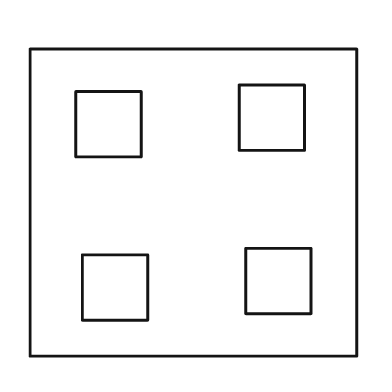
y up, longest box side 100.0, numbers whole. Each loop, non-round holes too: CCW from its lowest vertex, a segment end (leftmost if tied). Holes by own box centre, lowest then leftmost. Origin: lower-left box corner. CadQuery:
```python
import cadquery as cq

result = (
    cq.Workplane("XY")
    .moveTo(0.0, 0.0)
    .lineTo(100.0, 0.0)
    .lineTo(100.0, 94.0)
    .lineTo(0.0, 94.0)
    .close()
    .moveTo(16.0, 11.0)
    .lineTo(36.0, 11.0)
    .lineTo(36.0, 31.0)
    .lineTo(16.0, 31.0)
    .close()
    .moveTo(66.0, 13.0)
    .lineTo(86.0, 13.0)
    .lineTo(86.0, 33.0)
    .lineTo(66.0, 33.0)
    .close()
    .moveTo(14.0, 61.0)
    .lineTo(34.0, 61.0)
    .lineTo(34.0, 81.0)
    .lineTo(14.0, 81.0)
    .close()
    .moveTo(64.0, 63.0)
    .lineTo(84.0, 63.0)
    .lineTo(84.0, 83.0)
    .lineTo(64.0, 83.0)
    .close()
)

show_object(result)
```